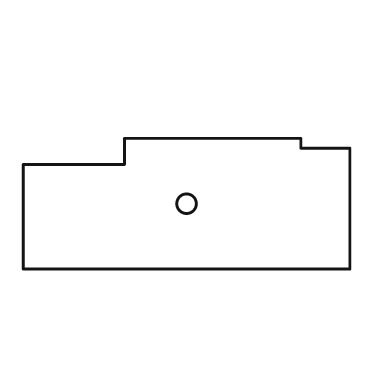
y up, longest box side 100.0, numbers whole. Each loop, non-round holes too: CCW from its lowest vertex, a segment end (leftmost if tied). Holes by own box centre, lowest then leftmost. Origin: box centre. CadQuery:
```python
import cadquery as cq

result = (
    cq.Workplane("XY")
    .moveTo(-50.0, -20.0)
    .lineTo(50.0, -20.0)
    .lineTo(50.0, 17.0)
    .lineTo(35.0, 17.0)
    .lineTo(35.0, 20.0)
    .lineTo(-19.0, 20.0)
    .lineTo(-19.0, 12.0)
    .lineTo(-50.0, 12.0)
    .close()
    .moveTo(0.0, 0.0)
    .circle(3.0)
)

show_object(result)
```